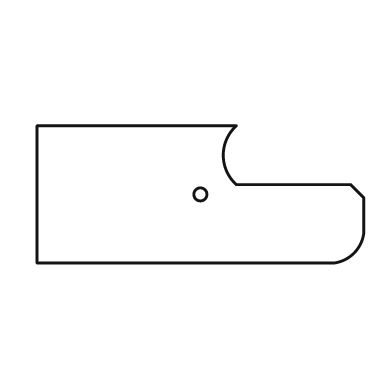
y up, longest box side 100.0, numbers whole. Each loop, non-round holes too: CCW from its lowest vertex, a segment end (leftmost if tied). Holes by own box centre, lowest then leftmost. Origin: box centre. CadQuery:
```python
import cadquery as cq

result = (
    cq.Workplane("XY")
    .moveTo(-50.0, -21.0)
    .lineTo(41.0, -21.0)
    .threePointArc((47.0, -18.0), (50.0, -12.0))
    .lineTo(50.0, -1.0)
    .lineTo(46.0, 3.0)
    .lineTo(11.0, 3.0)
    .threePointArc((7.0, 12.0), (11.0, 21.0))
    .lineTo(-50.0, 21.0)
    .close()
    .moveTo(0.0, 0.0)
    .circle(2.0)
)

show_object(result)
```